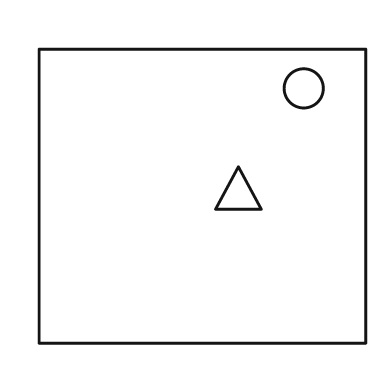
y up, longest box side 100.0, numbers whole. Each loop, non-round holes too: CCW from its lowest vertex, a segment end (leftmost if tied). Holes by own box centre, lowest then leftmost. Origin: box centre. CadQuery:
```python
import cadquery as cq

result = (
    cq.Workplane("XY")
    .moveTo(-50.0, -45.0)
    .lineTo(50.0, -45.0)
    .lineTo(50.0, 45.0)
    .lineTo(-50.0, 45.0)
    .close()
    .moveTo(4.0, -4.0)
    .lineTo(18.0, -4.0)
    .lineTo(11.0, 9.0)
    .close()
    .moveTo(31.0, 33.0)
    .circle(6.0)
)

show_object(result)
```